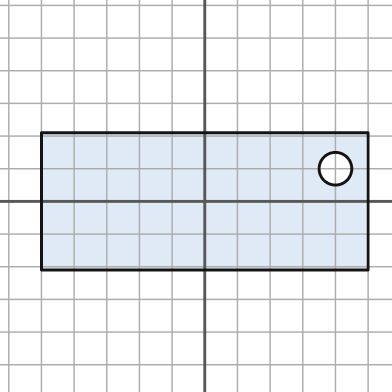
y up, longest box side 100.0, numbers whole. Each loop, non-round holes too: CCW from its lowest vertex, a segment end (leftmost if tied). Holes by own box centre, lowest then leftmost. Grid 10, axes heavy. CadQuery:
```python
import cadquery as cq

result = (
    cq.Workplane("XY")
    .moveTo(-50.0, -21.0)
    .lineTo(50.0, -21.0)
    .lineTo(50.0, 21.0)
    .lineTo(-50.0, 21.0)
    .close()
    .moveTo(40.0, 10.0)
    .circle(5.0)
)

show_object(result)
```